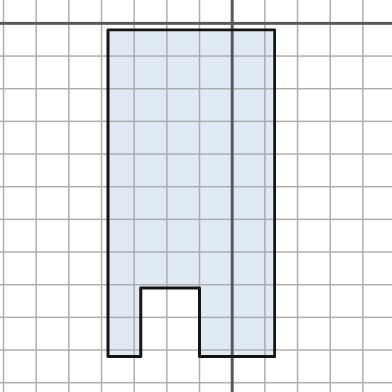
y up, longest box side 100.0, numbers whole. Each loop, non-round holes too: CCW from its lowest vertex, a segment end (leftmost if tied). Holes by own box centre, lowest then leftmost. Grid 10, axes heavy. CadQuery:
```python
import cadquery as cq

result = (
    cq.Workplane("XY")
    .moveTo(-38.0, -102.0)
    .lineTo(-28.0, -102.0)
    .lineTo(-28.0, -81.0)
    .lineTo(-10.0, -81.0)
    .lineTo(-10.0, -102.0)
    .lineTo(13.0, -102.0)
    .lineTo(13.0, -2.0)
    .lineTo(-38.0, -2.0)
    .close()
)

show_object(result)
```